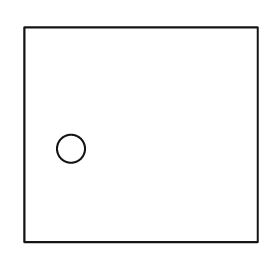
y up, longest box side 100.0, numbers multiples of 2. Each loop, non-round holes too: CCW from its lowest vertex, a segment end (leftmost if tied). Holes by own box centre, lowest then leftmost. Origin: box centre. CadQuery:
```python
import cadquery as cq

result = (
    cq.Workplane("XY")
    .moveTo(-50.0, -46.0)
    .lineTo(50.0, -46.0)
    .lineTo(50.0, 46.0)
    .lineTo(-50.0, 46.0)
    .close()
    .moveTo(-30.0, -6.0)
    .circle(6.0)
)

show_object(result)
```